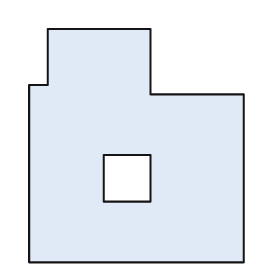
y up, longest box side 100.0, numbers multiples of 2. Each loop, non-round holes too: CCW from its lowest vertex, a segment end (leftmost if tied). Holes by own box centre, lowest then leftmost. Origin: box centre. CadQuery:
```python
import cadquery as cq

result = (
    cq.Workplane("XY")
    .moveTo(-46.0, -50.0)
    .lineTo(46.0, -50.0)
    .lineTo(46.0, 22.0)
    .lineTo(6.0, 22.0)
    .lineTo(6.0, 50.0)
    .lineTo(-38.0, 50.0)
    .lineTo(-38.0, 26.0)
    .lineTo(-46.0, 26.0)
    .close()
    .moveTo(-14.0, -24.0)
    .lineTo(6.0, -24.0)
    .lineTo(6.0, -4.0)
    .lineTo(-14.0, -4.0)
    .close()
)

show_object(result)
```